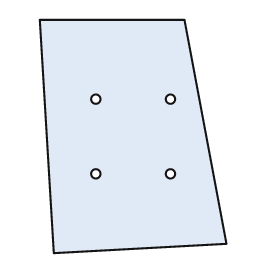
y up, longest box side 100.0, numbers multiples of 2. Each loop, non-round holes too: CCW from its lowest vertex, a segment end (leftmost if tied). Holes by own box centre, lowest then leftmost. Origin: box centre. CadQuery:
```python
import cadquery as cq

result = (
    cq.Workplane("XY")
    .moveTo(-34.0, -50.0)
    .lineTo(40.0, -46.0)
    .lineTo(22.0, 50.0)
    .lineTo(-40.0, 50.0)
    .close()
    .moveTo(-16.0, -16.0)
    .circle(2.0)
    .moveTo(16.0, -16.0)
    .circle(2.0)
    .moveTo(-16.0, 16.0)
    .circle(2.0)
    .moveTo(16.0, 16.0)
    .circle(2.0)
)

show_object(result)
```